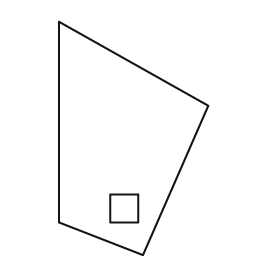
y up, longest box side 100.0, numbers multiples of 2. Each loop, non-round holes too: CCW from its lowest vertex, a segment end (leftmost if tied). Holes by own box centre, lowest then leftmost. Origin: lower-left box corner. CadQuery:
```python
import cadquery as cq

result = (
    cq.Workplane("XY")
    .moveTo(36.0, 0.0)
    .lineTo(64.0, 64.0)
    .lineTo(0.0, 100.0)
    .lineTo(0.0, 14.0)
    .close()
    .moveTo(22.0, 14.0)
    .lineTo(34.0, 14.0)
    .lineTo(34.0, 26.0)
    .lineTo(22.0, 26.0)
    .close()
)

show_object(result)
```